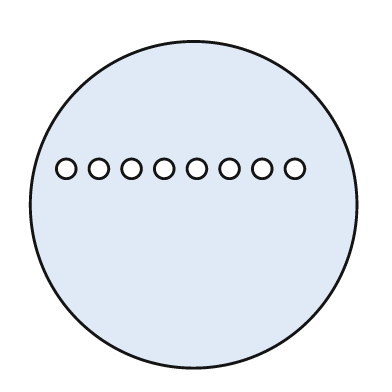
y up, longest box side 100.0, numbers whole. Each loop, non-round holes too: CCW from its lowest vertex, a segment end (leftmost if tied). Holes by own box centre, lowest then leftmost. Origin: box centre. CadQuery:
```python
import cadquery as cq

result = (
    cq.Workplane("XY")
    .moveTo(0.0, 0.0)
    .circle(50.0)
    .moveTo(-39.0, 11.0)
    .circle(3.0)
    .moveTo(-29.0, 11.0)
    .circle(3.0)
    .moveTo(-19.0, 11.0)
    .circle(3.0)
    .moveTo(-9.0, 11.0)
    .circle(3.0)
    .moveTo(1.0, 11.0)
    .circle(3.0)
    .moveTo(11.0, 11.0)
    .circle(3.0)
    .moveTo(21.0, 11.0)
    .circle(3.0)
    .moveTo(31.0, 11.0)
    .circle(3.0)
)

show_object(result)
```